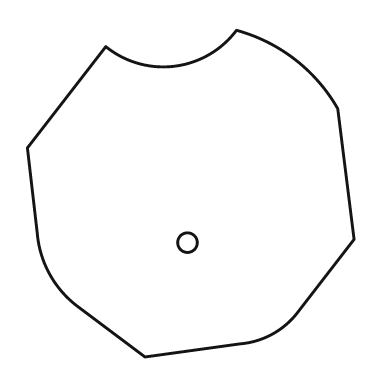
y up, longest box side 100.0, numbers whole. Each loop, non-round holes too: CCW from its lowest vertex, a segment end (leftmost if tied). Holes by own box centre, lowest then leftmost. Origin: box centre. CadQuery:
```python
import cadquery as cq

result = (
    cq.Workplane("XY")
    .moveTo(-14.0, -50.0)
    .lineTo(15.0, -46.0)
    .threePointArc((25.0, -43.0), (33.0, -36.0))
    .lineTo(50.0, -14.0)
    .lineTo(45.0, 26.0)
    .threePointArc((32.0, 41.0), (14.0, 50.0))
    .threePointArc((-5.0, 39.0), (-26.0, 45.0))
    .lineTo(-50.0, 14.0)
    .lineTo(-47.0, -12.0)
    .threePointArc((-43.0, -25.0), (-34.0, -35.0))
    .close()
    .moveTo(-1.0, -15.0)
    .circle(3.0)
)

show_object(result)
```